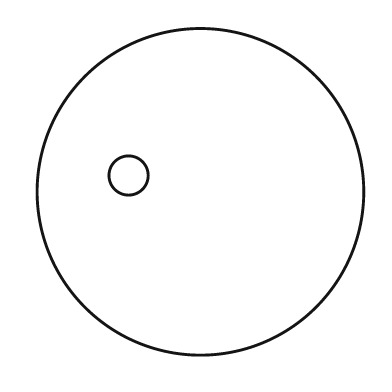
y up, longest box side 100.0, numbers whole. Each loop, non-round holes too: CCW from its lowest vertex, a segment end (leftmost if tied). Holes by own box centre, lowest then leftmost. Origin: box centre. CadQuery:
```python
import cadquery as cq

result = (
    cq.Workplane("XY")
    .moveTo(0.0, 0.0)
    .circle(50.0)
    .moveTo(-22.0, 5.0)
    .circle(6.0)
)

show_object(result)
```